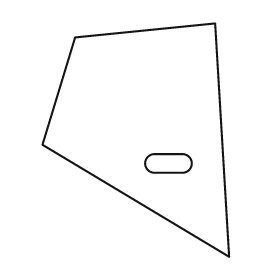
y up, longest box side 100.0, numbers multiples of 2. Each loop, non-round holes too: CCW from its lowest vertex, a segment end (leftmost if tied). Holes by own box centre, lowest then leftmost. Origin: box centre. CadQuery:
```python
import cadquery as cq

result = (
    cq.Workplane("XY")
    .moveTo(40.0, -50.0)
    .lineTo(34.0, 50.0)
    .lineTo(-26.0, 44.0)
    .lineTo(-40.0, -2.0)
    .close()
    .moveTo(8.0, -14.0)
    .lineTo(20.0, -14.0)
    .threePointArc((24.0, -10.0), (20.0, -6.0))
    .lineTo(8.0, -6.0)
    .threePointArc((4.0, -10.0), (8.0, -14.0))
    .close()
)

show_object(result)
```